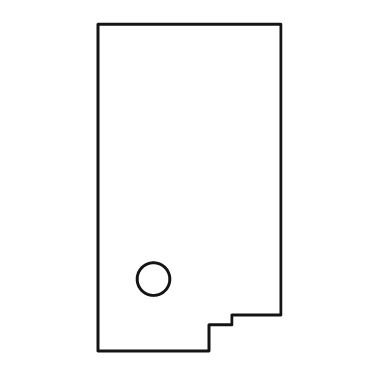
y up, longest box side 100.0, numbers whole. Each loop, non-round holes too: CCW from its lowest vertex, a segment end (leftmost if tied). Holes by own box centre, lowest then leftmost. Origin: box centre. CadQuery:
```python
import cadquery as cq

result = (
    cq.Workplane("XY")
    .moveTo(-28.0, -50.0)
    .lineTo(6.0, -50.0)
    .lineTo(6.0, -42.0)
    .lineTo(13.0, -42.0)
    .lineTo(13.0, -39.0)
    .lineTo(28.0, -39.0)
    .lineTo(28.0, 50.0)
    .lineTo(-28.0, 50.0)
    .close()
    .moveTo(-11.0, -28.0)
    .circle(5.0)
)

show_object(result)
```